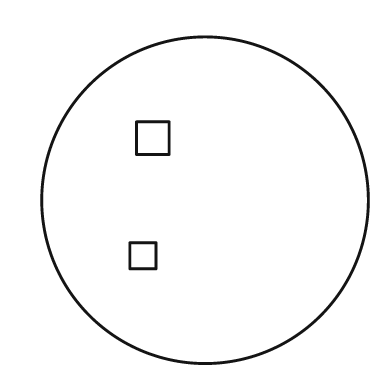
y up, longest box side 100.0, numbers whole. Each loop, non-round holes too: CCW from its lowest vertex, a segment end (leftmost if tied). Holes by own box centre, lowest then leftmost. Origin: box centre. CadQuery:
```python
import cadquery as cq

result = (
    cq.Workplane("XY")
    .moveTo(0.0, 0.0)
    .circle(50.0)
    .moveTo(-23.0, -21.0)
    .lineTo(-15.0, -21.0)
    .lineTo(-15.0, -13.0)
    .lineTo(-23.0, -13.0)
    .close()
    .moveTo(-21.0, 14.0)
    .lineTo(-11.0, 14.0)
    .lineTo(-11.0, 24.0)
    .lineTo(-21.0, 24.0)
    .close()
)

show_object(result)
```